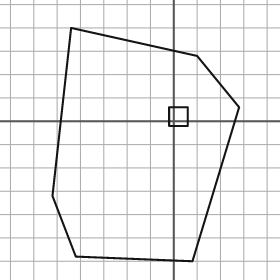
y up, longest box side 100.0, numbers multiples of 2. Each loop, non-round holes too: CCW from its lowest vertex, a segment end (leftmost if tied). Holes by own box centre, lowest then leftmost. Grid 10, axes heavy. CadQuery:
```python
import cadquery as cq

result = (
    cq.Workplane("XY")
    .moveTo(8.0, -60.0)
    .lineTo(28.0, 6.0)
    .lineTo(10.0, 28.0)
    .lineTo(-44.0, 40.0)
    .lineTo(-52.0, -32.0)
    .lineTo(-42.0, -58.0)
    .close()
    .moveTo(-2.0, -2.0)
    .lineTo(6.0, -2.0)
    .lineTo(6.0, 6.0)
    .lineTo(-2.0, 6.0)
    .close()
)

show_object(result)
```